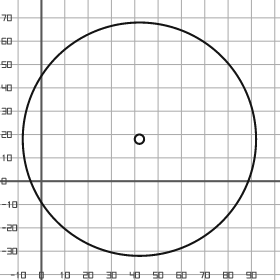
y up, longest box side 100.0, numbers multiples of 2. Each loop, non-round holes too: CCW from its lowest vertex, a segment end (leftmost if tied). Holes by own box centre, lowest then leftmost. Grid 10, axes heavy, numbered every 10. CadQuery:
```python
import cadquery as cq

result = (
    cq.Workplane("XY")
    .moveTo(42.0, 18.0)
    .circle(50.0)
    .moveTo(42.0, 18.0)
    .circle(2.0)
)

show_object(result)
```